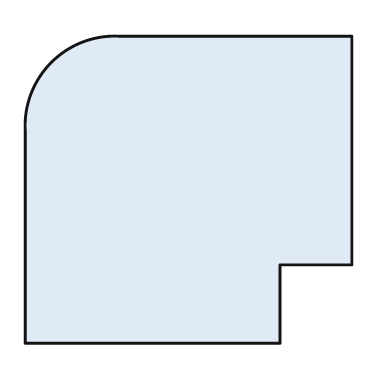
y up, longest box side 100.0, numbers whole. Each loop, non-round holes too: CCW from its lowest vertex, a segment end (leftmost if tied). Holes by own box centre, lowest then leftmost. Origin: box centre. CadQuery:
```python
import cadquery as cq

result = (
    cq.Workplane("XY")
    .moveTo(-50.0, -47.0)
    .lineTo(28.0, -47.0)
    .lineTo(28.0, -23.0)
    .lineTo(50.0, -23.0)
    .lineTo(50.0, 47.0)
    .lineTo(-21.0, 47.0)
    .threePointArc((-42.0, 39.0), (-50.0, 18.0))
    .close()
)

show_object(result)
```